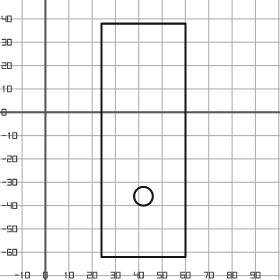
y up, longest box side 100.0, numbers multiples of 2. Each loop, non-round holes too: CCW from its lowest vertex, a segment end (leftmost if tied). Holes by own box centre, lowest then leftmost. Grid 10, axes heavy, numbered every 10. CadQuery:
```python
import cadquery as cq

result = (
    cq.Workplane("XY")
    .moveTo(24.0, -62.0)
    .lineTo(60.0, -62.0)
    .lineTo(60.0, 38.0)
    .lineTo(24.0, 38.0)
    .close()
    .moveTo(42.0, -36.0)
    .circle(4.0)
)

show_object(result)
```